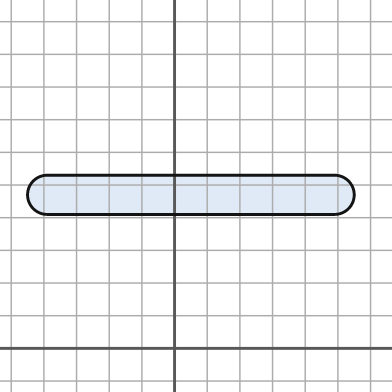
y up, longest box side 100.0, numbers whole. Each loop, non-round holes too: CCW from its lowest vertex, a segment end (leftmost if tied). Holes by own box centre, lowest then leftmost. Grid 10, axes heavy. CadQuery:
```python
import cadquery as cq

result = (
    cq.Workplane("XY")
    .moveTo(-39.0, 41.0)
    .lineTo(49.0, 41.0)
    .threePointArc((55.0, 47.0), (49.0, 53.0))
    .lineTo(-39.0, 53.0)
    .threePointArc((-45.0, 47.0), (-39.0, 41.0))
    .close()
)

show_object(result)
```